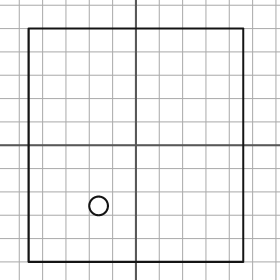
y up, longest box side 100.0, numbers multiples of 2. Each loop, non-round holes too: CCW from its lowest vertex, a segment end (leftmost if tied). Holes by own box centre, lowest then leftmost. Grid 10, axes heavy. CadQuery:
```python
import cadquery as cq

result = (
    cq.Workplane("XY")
    .moveTo(-46.0, -50.0)
    .lineTo(46.0, -50.0)
    .lineTo(46.0, 50.0)
    .lineTo(-46.0, 50.0)
    .close()
    .moveTo(-16.0, -26.0)
    .circle(4.0)
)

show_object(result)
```